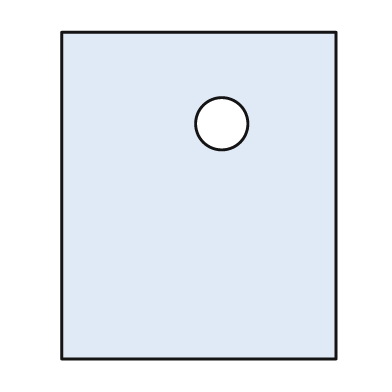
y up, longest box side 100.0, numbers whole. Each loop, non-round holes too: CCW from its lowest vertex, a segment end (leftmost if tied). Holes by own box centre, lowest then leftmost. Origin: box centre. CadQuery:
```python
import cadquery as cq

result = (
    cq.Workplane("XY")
    .moveTo(-42.0, -50.0)
    .lineTo(42.0, -50.0)
    .lineTo(42.0, 50.0)
    .lineTo(-42.0, 50.0)
    .close()
    .moveTo(7.0, 22.0)
    .circle(8.0)
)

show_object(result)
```